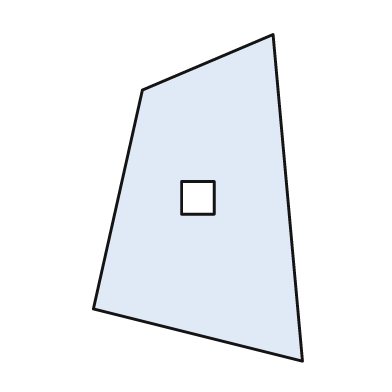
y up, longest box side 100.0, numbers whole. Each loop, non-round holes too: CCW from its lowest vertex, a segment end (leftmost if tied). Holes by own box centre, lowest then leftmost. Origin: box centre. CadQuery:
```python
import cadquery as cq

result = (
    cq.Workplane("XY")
    .moveTo(32.0, -50.0)
    .lineTo(23.0, 50.0)
    .lineTo(-17.0, 33.0)
    .lineTo(-32.0, -34.0)
    .close()
    .moveTo(-5.0, -5.0)
    .lineTo(5.0, -5.0)
    .lineTo(5.0, 5.0)
    .lineTo(-5.0, 5.0)
    .close()
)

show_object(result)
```